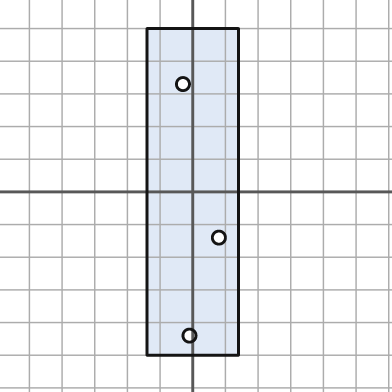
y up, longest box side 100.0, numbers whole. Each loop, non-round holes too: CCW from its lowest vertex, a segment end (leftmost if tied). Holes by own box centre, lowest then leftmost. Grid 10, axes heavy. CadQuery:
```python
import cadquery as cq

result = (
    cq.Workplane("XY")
    .moveTo(-14.0, -50.0)
    .lineTo(14.0, -50.0)
    .lineTo(14.0, 50.0)
    .lineTo(-14.0, 50.0)
    .close()
    .moveTo(-1.0, -44.0)
    .circle(2.0)
    .moveTo(8.0, -14.0)
    .circle(2.0)
    .moveTo(-3.0, 33.0)
    .circle(2.0)
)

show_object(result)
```